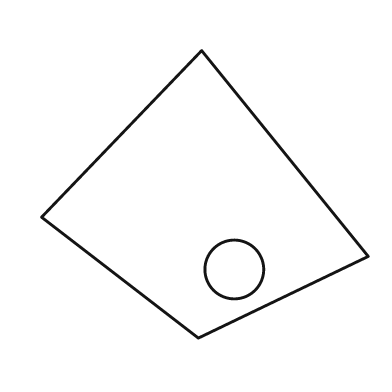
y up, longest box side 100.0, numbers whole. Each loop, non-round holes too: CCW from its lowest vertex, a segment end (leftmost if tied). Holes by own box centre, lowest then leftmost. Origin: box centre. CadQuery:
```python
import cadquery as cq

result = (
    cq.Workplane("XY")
    .moveTo(-2.0, -44.0)
    .lineTo(50.0, -19.0)
    .lineTo(-1.0, 44.0)
    .lineTo(-50.0, -7.0)
    .close()
    .moveTo(9.0, -23.0)
    .circle(9.0)
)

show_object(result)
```